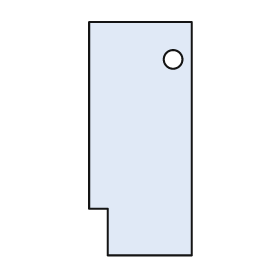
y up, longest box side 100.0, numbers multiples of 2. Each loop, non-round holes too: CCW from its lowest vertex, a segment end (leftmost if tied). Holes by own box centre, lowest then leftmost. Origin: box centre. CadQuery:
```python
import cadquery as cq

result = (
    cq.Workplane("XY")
    .moveTo(-14.0, -50.0)
    .lineTo(22.0, -50.0)
    .lineTo(22.0, 50.0)
    .lineTo(-22.0, 50.0)
    .lineTo(-22.0, -30.0)
    .lineTo(-14.0, -30.0)
    .close()
    .moveTo(14.0, 34.0)
    .circle(4.0)
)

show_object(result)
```